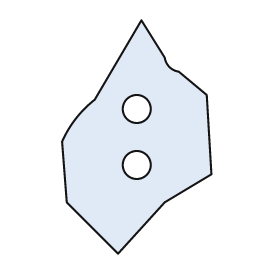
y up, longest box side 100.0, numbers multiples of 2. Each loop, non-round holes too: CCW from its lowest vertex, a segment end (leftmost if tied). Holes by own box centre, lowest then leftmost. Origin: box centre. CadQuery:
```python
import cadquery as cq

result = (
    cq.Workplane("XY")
    .moveTo(-8.0, -50.0)
    .lineTo(12.0, -28.0)
    .lineTo(32.0, -16.0)
    .lineTo(30.0, 18.0)
    .lineTo(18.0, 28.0)
    .threePointArc((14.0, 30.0), (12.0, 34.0))
    .lineTo(2.0, 50.0)
    .lineTo(-18.0, 16.0)
    .threePointArc((-26.0, 8.0), (-32.0, -2.0))
    .lineTo(-30.0, -28.0)
    .close()
    .moveTo(0.0, -12.0)
    .circle(6.0)
    .moveTo(0.0, 12.0)
    .circle(6.0)
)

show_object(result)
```